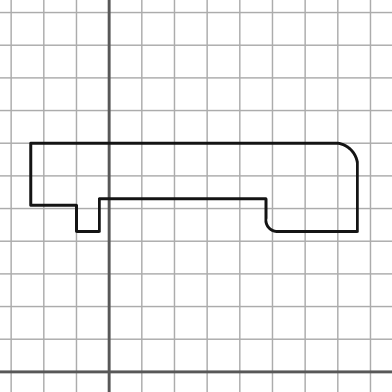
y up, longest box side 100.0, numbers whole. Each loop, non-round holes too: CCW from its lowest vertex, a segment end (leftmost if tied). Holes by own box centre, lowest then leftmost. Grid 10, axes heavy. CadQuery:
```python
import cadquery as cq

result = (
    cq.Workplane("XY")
    .moveTo(-10.0, 43.0)
    .lineTo(-3.0, 43.0)
    .lineTo(-3.0, 53.0)
    .lineTo(48.0, 53.0)
    .lineTo(48.0, 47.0)
    .threePointArc((49.0, 44.0), (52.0, 43.0))
    .lineTo(76.0, 43.0)
    .lineTo(76.0, 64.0)
    .threePointArc((74.0, 68.0), (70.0, 70.0))
    .lineTo(-24.0, 70.0)
    .lineTo(-24.0, 51.0)
    .lineTo(-10.0, 51.0)
    .close()
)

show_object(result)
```